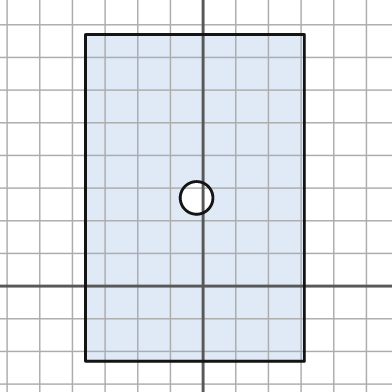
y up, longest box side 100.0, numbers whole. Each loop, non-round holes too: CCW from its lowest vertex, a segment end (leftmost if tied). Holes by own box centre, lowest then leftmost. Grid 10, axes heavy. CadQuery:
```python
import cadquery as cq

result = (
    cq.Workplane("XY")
    .moveTo(-36.0, -23.0)
    .lineTo(31.0, -23.0)
    .lineTo(31.0, 77.0)
    .lineTo(-36.0, 77.0)
    .close()
    .moveTo(-2.0, 27.0)
    .circle(5.0)
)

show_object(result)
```